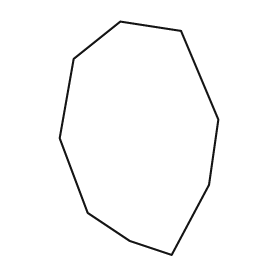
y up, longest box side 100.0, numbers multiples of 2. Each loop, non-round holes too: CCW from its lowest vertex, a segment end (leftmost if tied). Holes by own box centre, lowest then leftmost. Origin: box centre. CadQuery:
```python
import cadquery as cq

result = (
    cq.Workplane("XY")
    .moveTo(14.0, -50.0)
    .lineTo(30.0, -20.0)
    .lineTo(34.0, 8.0)
    .lineTo(18.0, 46.0)
    .lineTo(-8.0, 50.0)
    .lineTo(-28.0, 34.0)
    .lineTo(-34.0, 0.0)
    .lineTo(-22.0, -32.0)
    .lineTo(-4.0, -44.0)
    .close()
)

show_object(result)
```